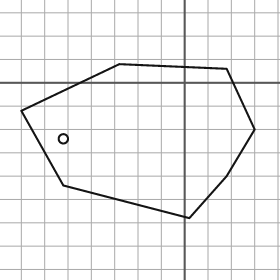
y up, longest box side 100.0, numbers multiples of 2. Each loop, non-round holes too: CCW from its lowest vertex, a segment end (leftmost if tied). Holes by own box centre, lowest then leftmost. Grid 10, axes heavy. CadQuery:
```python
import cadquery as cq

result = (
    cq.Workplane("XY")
    .moveTo(2.0, -58.0)
    .lineTo(18.0, -40.0)
    .lineTo(30.0, -20.0)
    .lineTo(18.0, 6.0)
    .lineTo(-28.0, 8.0)
    .lineTo(-70.0, -12.0)
    .lineTo(-52.0, -44.0)
    .close()
    .moveTo(-52.0, -24.0)
    .circle(2.0)
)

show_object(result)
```